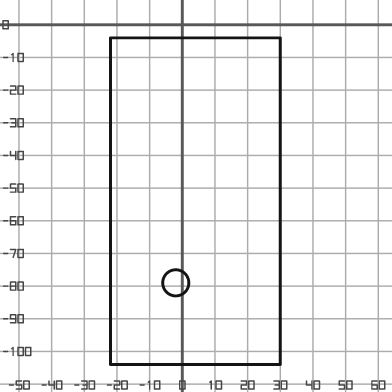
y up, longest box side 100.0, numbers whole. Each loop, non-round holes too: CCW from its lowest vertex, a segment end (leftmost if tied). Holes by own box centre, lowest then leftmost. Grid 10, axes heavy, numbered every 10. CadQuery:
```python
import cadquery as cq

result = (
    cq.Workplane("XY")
    .moveTo(-22.0, -104.0)
    .lineTo(30.0, -104.0)
    .lineTo(30.0, -4.0)
    .lineTo(-22.0, -4.0)
    .close()
    .moveTo(-2.0, -79.0)
    .circle(4.0)
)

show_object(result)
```